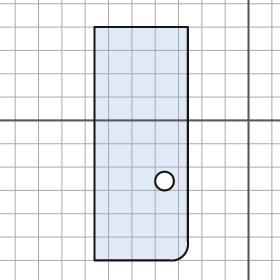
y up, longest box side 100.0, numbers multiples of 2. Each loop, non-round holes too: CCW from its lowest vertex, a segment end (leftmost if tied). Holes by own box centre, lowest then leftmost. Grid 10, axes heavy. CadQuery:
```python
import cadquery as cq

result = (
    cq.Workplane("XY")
    .moveTo(-66.0, -60.0)
    .lineTo(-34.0, -60.0)
    .threePointArc((-28.0, -58.0), (-26.0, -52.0))
    .lineTo(-26.0, 40.0)
    .lineTo(-66.0, 40.0)
    .close()
    .moveTo(-36.0, -26.0)
    .circle(4.0)
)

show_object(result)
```